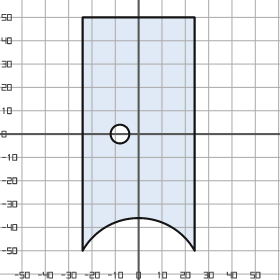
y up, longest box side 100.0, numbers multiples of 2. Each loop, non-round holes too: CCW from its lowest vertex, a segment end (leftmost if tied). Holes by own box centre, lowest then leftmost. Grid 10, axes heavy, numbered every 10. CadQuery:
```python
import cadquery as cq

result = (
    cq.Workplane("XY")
    .moveTo(-24.0, -50.0)
    .threePointArc((0.0, -36.0), (24.0, -50.0))
    .lineTo(24.0, 50.0)
    .lineTo(-24.0, 50.0)
    .close()
    .moveTo(-8.0, 0.0)
    .circle(4.0)
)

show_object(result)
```